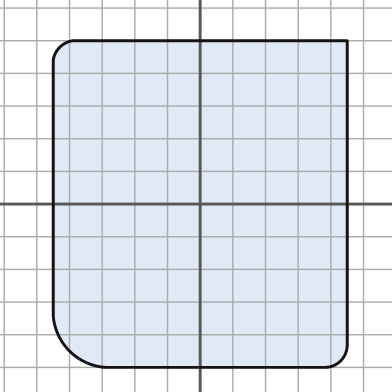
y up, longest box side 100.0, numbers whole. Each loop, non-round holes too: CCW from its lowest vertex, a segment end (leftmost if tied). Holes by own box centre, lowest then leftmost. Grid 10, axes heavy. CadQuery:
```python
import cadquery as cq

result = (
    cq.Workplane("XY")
    .moveTo(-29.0, -50.0)
    .lineTo(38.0, -50.0)
    .threePointArc((43.0, -48.0), (45.0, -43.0))
    .lineTo(45.0, 50.0)
    .lineTo(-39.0, 50.0)
    .threePointArc((-43.0, 48.0), (-45.0, 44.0))
    .lineTo(-45.0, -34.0)
    .threePointArc((-40.0, -45.0), (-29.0, -50.0))
    .close()
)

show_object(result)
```